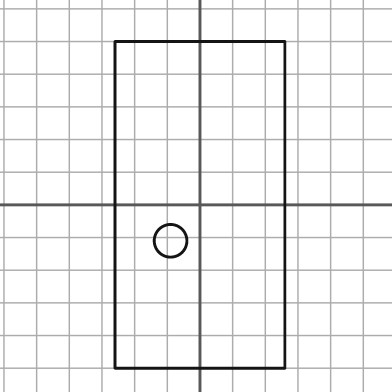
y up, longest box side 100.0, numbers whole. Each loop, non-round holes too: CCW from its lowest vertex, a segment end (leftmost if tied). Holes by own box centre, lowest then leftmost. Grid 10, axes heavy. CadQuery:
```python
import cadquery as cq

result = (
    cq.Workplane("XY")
    .moveTo(-26.0, -50.0)
    .lineTo(26.0, -50.0)
    .lineTo(26.0, 50.0)
    .lineTo(-26.0, 50.0)
    .close()
    .moveTo(-9.0, -11.0)
    .circle(5.0)
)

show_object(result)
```